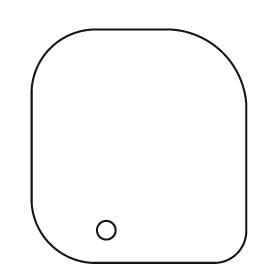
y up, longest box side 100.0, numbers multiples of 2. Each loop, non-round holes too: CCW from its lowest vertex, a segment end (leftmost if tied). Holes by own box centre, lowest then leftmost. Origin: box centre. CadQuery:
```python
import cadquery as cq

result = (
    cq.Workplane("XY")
    .moveTo(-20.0, -50.0)
    .lineTo(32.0, -50.0)
    .threePointArc((42.0, -46.0), (46.0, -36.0))
    .lineTo(46.0, 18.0)
    .threePointArc((36.0, 40.0), (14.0, 50.0))
    .lineTo(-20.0, 50.0)
    .threePointArc((-38.0, 42.0), (-46.0, 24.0))
    .lineTo(-46.0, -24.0)
    .threePointArc((-38.0, -42.0), (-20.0, -50.0))
    .close()
    .moveTo(-14.0, -36.0)
    .circle(4.0)
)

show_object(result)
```